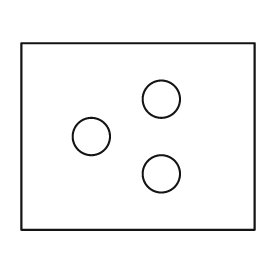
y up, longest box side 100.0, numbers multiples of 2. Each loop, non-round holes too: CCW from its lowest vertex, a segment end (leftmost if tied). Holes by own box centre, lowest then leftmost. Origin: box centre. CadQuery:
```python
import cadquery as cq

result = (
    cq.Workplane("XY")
    .moveTo(-50.0, -40.0)
    .lineTo(50.0, -40.0)
    .lineTo(50.0, 40.0)
    .lineTo(-50.0, 40.0)
    .close()
    .moveTo(10.0, -16.0)
    .circle(8.0)
    .moveTo(-20.0, 0.0)
    .circle(8.0)
    .moveTo(10.0, 16.0)
    .circle(8.0)
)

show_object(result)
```